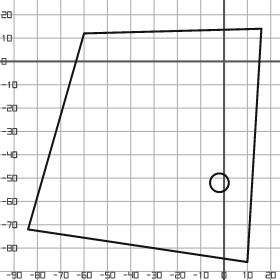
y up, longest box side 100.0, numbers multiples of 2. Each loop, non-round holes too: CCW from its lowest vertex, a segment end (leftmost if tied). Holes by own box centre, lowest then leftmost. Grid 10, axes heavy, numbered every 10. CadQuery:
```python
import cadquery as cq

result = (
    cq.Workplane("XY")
    .moveTo(10.0, -86.0)
    .lineTo(16.0, 14.0)
    .lineTo(-60.0, 12.0)
    .lineTo(-84.0, -72.0)
    .close()
    .moveTo(-2.0, -52.0)
    .circle(4.0)
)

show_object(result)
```